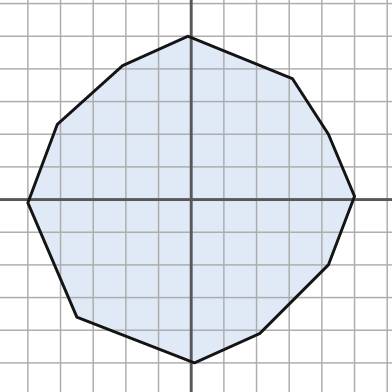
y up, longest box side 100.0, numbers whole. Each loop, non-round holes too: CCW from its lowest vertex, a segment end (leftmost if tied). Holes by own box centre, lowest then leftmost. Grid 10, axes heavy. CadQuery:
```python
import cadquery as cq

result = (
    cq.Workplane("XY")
    .moveTo(1.0, -50.0)
    .lineTo(21.0, -41.0)
    .lineTo(42.0, -20.0)
    .lineTo(50.0, 1.0)
    .lineTo(42.0, 20.0)
    .lineTo(31.0, 37.0)
    .lineTo(-1.0, 50.0)
    .lineTo(-21.0, 41.0)
    .lineTo(-41.0, 23.0)
    .lineTo(-50.0, -1.0)
    .lineTo(-35.0, -36.0)
    .close()
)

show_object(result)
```